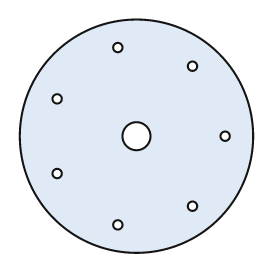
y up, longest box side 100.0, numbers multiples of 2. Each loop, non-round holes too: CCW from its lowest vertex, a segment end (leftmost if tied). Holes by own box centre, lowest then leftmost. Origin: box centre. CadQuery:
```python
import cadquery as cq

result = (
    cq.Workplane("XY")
    .moveTo(0.0, 0.0)
    .circle(50.0)
    .moveTo(-8.0, -38.0)
    .circle(2.0)
    .moveTo(24.0, -30.0)
    .circle(2.0)
    .moveTo(-34.0, -16.0)
    .circle(2.0)
    .moveTo(0.0, 0.0)
    .circle(6.0)
    .moveTo(38.0, 0.0)
    .circle(2.0)
    .moveTo(-34.0, 16.0)
    .circle(2.0)
    .moveTo(24.0, 30.0)
    .circle(2.0)
    .moveTo(-8.0, 38.0)
    .circle(2.0)
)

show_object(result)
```